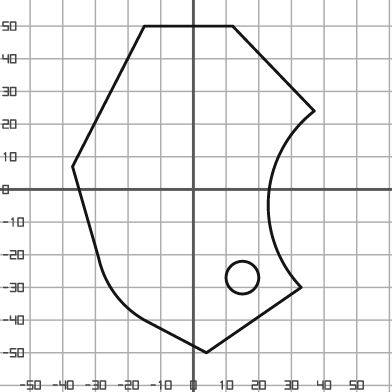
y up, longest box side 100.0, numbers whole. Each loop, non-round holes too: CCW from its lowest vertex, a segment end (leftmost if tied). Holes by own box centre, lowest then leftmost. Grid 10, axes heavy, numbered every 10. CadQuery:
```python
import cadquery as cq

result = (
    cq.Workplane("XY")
    .moveTo(4.0, -50.0)
    .lineTo(33.0, -30.0)
    .threePointArc((23.0, -2.0), (37.0, 24.0))
    .lineTo(12.0, 50.0)
    .lineTo(-15.0, 50.0)
    .lineTo(-37.0, 7.0)
    .lineTo(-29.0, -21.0)
    .threePointArc((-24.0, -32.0), (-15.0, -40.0))
    .close()
    .moveTo(15.0, -27.0)
    .circle(5.0)
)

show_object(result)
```